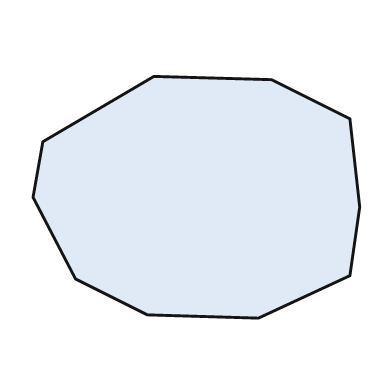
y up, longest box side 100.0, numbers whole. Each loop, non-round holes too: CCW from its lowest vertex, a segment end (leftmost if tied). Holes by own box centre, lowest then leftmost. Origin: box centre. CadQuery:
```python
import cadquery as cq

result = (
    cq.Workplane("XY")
    .moveTo(19.0, -37.0)
    .lineTo(47.0, -24.0)
    .lineTo(50.0, -3.0)
    .lineTo(47.0, 24.0)
    .lineTo(23.0, 36.0)
    .lineTo(-13.0, 37.0)
    .lineTo(-47.0, 17.0)
    .lineTo(-50.0, 0.0)
    .lineTo(-37.0, -25.0)
    .lineTo(-15.0, -36.0)
    .close()
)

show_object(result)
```